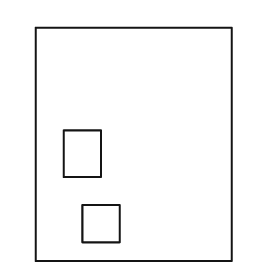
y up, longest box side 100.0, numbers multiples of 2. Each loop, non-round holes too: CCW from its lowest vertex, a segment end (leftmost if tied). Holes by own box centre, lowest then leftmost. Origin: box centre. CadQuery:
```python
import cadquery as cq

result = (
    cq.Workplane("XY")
    .moveTo(-42.0, -50.0)
    .lineTo(42.0, -50.0)
    .lineTo(42.0, 50.0)
    .lineTo(-42.0, 50.0)
    .close()
    .moveTo(-22.0, -42.0)
    .lineTo(-6.0, -42.0)
    .lineTo(-6.0, -26.0)
    .lineTo(-22.0, -26.0)
    .close()
    .moveTo(-30.0, -14.0)
    .lineTo(-14.0, -14.0)
    .lineTo(-14.0, 6.0)
    .lineTo(-30.0, 6.0)
    .close()
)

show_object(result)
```